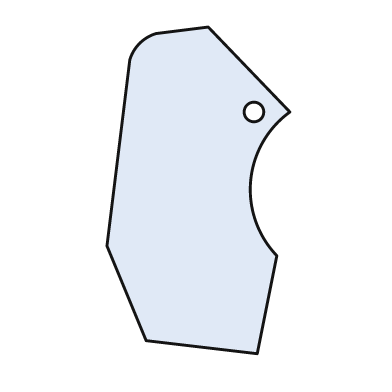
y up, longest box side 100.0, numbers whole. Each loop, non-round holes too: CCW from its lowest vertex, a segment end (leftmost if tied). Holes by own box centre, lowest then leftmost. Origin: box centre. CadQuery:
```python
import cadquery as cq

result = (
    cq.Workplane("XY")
    .moveTo(18.0, -50.0)
    .lineTo(24.0, -20.0)
    .threePointArc((16.0, 3.0), (28.0, 24.0))
    .lineTo(3.0, 50.0)
    .lineTo(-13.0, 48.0)
    .threePointArc((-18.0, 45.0), (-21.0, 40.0))
    .lineTo(-28.0, -17.0)
    .lineTo(-16.0, -46.0)
    .close()
    .moveTo(17.0, 24.0)
    .circle(3.0)
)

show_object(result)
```